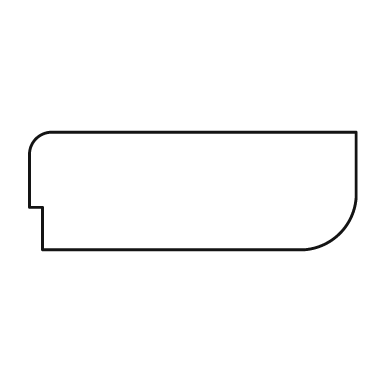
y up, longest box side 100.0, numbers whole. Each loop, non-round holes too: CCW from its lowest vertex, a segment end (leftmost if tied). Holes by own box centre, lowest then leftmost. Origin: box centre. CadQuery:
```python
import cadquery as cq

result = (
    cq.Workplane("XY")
    .moveTo(-46.0, -18.0)
    .lineTo(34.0, -18.0)
    .threePointArc((45.0, -13.0), (50.0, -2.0))
    .lineTo(50.0, 18.0)
    .lineTo(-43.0, 18.0)
    .threePointArc((-48.0, 16.0), (-50.0, 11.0))
    .lineTo(-50.0, -5.0)
    .lineTo(-46.0, -5.0)
    .close()
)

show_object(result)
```